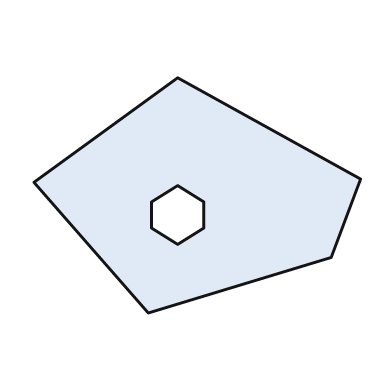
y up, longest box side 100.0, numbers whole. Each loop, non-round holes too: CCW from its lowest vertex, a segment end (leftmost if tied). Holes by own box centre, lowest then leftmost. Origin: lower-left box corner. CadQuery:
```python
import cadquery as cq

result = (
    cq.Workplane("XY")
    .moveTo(35.0, 0.0)
    .lineTo(91.0, 17.0)
    .lineTo(100.0, 41.0)
    .lineTo(44.0, 72.0)
    .lineTo(0.0, 40.0)
    .close()
    .moveTo(44.0, 21.0)
    .lineTo(52.0, 26.0)
    .lineTo(52.0, 34.0)
    .lineTo(44.0, 39.0)
    .lineTo(36.0, 34.0)
    .lineTo(36.0, 26.0)
    .close()
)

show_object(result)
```